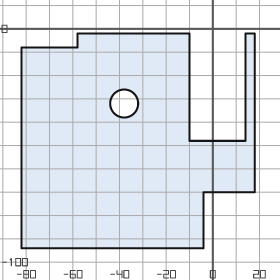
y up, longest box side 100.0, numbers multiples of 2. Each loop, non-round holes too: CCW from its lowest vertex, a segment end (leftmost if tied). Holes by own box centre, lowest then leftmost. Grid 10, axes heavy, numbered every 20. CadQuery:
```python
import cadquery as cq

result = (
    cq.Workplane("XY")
    .moveTo(-82.0, -94.0)
    .lineTo(-4.0, -94.0)
    .lineTo(-4.0, -70.0)
    .lineTo(18.0, -70.0)
    .lineTo(18.0, -2.0)
    .lineTo(14.0, -2.0)
    .lineTo(14.0, -48.0)
    .lineTo(-10.0, -48.0)
    .lineTo(-10.0, -2.0)
    .lineTo(-58.0, -2.0)
    .lineTo(-58.0, -8.0)
    .lineTo(-82.0, -8.0)
    .close()
    .moveTo(-38.0, -32.0)
    .circle(6.0)
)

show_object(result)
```